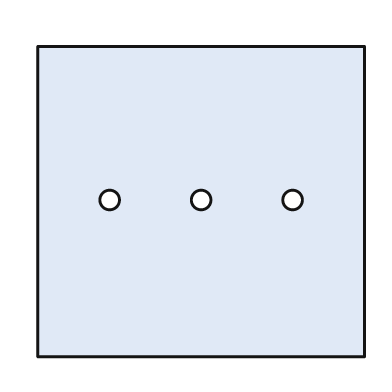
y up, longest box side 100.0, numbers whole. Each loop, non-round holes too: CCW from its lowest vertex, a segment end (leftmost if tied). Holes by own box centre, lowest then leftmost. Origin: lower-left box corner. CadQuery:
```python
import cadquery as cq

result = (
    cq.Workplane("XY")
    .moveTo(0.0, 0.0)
    .lineTo(100.0, 0.0)
    .lineTo(100.0, 95.0)
    .lineTo(0.0, 95.0)
    .close()
    .moveTo(22.0, 48.0)
    .circle(3.0)
    .moveTo(50.0, 48.0)
    .circle(3.0)
    .moveTo(78.0, 48.0)
    .circle(3.0)
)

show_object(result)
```